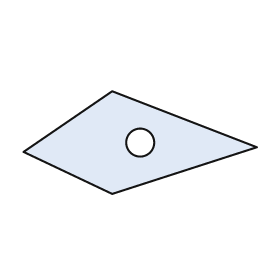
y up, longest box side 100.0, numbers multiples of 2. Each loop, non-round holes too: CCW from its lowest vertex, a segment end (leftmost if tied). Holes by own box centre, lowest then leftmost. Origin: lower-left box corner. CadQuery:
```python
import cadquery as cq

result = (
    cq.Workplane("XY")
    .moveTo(38.0, 0.0)
    .lineTo(100.0, 20.0)
    .lineTo(38.0, 44.0)
    .lineTo(0.0, 18.0)
    .close()
    .moveTo(50.0, 22.0)
    .circle(6.0)
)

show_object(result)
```